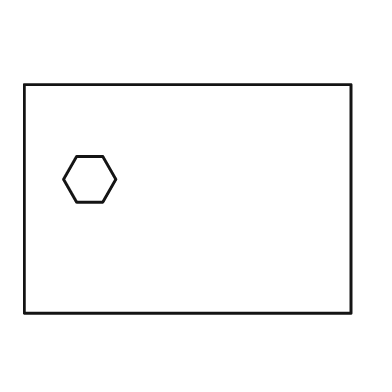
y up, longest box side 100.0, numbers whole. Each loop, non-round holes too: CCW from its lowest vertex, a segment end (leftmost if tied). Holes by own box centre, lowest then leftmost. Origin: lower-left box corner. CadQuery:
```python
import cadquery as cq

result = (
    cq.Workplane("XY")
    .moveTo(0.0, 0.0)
    .lineTo(100.0, 0.0)
    .lineTo(100.0, 70.0)
    .lineTo(0.0, 70.0)
    .close()
    .moveTo(16.0, 34.0)
    .lineTo(24.0, 34.0)
    .lineTo(28.0, 41.0)
    .lineTo(24.0, 48.0)
    .lineTo(16.0, 48.0)
    .lineTo(12.0, 41.0)
    .close()
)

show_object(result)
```